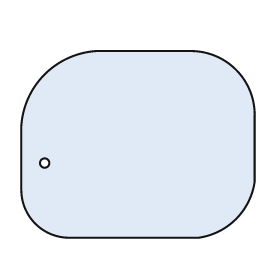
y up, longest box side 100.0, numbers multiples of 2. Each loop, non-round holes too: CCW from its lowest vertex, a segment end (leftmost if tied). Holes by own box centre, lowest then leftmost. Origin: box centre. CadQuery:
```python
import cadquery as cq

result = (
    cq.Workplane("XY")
    .moveTo(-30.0, -40.0)
    .lineTo(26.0, -40.0)
    .threePointArc((42.0, -32.0), (50.0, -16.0))
    .lineTo(50.0, 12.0)
    .threePointArc((42.0, 32.0), (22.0, 40.0))
    .lineTo(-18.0, 40.0)
    .threePointArc((-40.0, 30.0), (-50.0, 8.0))
    .lineTo(-50.0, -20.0)
    .threePointArc((-44.0, -34.0), (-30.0, -40.0))
    .close()
    .moveTo(-40.0, -8.0)
    .circle(2.0)
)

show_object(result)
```